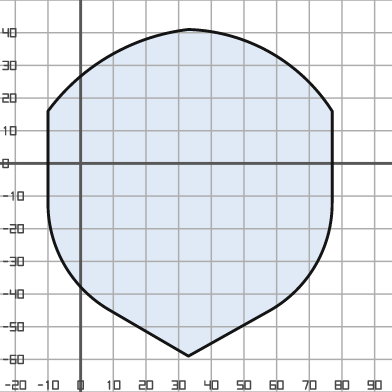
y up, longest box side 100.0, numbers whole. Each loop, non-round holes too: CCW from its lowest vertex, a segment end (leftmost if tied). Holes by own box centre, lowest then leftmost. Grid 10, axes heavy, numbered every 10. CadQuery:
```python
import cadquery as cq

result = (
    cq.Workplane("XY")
    .moveTo(33.0, -59.0)
    .lineTo(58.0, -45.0)
    .threePointArc((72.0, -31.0), (77.0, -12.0))
    .lineTo(77.0, 16.0)
    .threePointArc((58.0, 34.0), (33.0, 41.0))
    .threePointArc((9.0, 33.0), (-10.0, 16.0))
    .lineTo(-10.0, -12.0)
    .threePointArc((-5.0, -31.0), (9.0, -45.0))
    .close()
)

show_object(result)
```